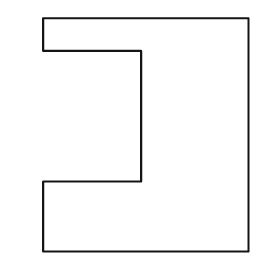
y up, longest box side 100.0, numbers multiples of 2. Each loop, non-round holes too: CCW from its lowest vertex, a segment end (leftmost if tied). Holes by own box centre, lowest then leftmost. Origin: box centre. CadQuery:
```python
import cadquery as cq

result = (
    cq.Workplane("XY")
    .moveTo(-44.0, -50.0)
    .lineTo(44.0, -50.0)
    .lineTo(44.0, 50.0)
    .lineTo(-44.0, 50.0)
    .lineTo(-44.0, 36.0)
    .lineTo(-2.0, 36.0)
    .lineTo(-2.0, -20.0)
    .lineTo(-44.0, -20.0)
    .close()
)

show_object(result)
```